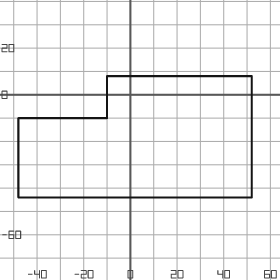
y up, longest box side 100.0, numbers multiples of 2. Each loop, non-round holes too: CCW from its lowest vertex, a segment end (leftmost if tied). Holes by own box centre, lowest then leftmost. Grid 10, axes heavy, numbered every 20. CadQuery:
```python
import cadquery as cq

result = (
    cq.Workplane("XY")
    .moveTo(-48.0, -44.0)
    .lineTo(52.0, -44.0)
    .lineTo(52.0, 8.0)
    .lineTo(-10.0, 8.0)
    .lineTo(-10.0, -10.0)
    .lineTo(-48.0, -10.0)
    .close()
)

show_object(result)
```